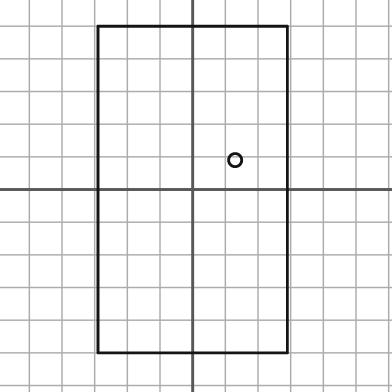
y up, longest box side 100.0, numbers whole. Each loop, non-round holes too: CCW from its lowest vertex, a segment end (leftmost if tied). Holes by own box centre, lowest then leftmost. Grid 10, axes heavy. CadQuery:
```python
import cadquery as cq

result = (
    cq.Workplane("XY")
    .moveTo(-29.0, -50.0)
    .lineTo(29.0, -50.0)
    .lineTo(29.0, 50.0)
    .lineTo(-29.0, 50.0)
    .close()
    .moveTo(13.0, 9.0)
    .circle(2.0)
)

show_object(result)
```